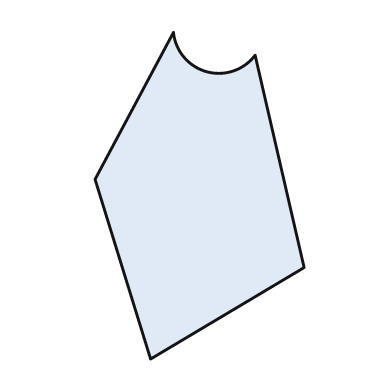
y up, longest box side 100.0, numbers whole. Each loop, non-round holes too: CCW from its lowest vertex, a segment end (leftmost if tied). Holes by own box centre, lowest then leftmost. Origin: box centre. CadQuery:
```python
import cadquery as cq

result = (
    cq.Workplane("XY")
    .moveTo(-15.0, -50.0)
    .lineTo(32.0, -22.0)
    .lineTo(17.0, 43.0)
    .threePointArc((2.0, 38.0), (-8.0, 50.0))
    .lineTo(-32.0, 5.0)
    .close()
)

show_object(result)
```